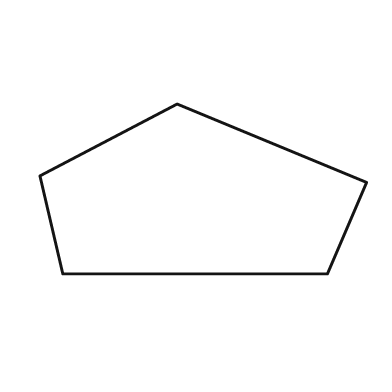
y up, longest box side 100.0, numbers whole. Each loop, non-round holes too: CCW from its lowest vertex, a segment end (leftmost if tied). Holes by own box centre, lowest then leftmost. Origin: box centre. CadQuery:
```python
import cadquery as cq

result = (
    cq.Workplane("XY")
    .moveTo(-43.0, -26.0)
    .lineTo(38.0, -26.0)
    .lineTo(50.0, 2.0)
    .lineTo(-8.0, 26.0)
    .lineTo(-50.0, 4.0)
    .close()
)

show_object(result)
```